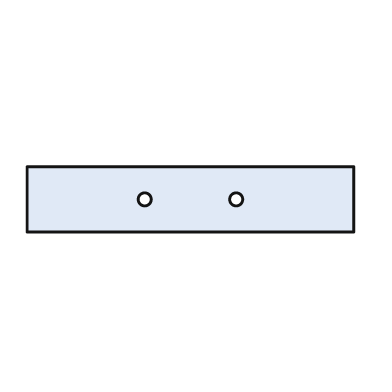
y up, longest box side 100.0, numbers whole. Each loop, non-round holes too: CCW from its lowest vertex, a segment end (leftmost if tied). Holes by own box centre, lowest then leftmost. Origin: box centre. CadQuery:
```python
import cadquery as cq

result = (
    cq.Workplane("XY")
    .moveTo(-50.0, -10.0)
    .lineTo(50.0, -10.0)
    .lineTo(50.0, 10.0)
    .lineTo(-50.0, 10.0)
    .close()
    .moveTo(-14.0, 0.0)
    .circle(2.0)
    .moveTo(14.0, 0.0)
    .circle(2.0)
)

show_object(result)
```